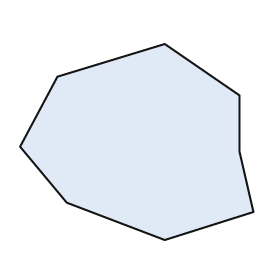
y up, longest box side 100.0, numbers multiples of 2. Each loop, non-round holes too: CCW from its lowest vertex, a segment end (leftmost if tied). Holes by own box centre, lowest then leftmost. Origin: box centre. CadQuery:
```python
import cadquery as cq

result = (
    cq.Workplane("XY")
    .moveTo(12.0, -42.0)
    .lineTo(50.0, -30.0)
    .lineTo(44.0, -4.0)
    .lineTo(44.0, 20.0)
    .lineTo(12.0, 42.0)
    .lineTo(-34.0, 28.0)
    .lineTo(-50.0, -2.0)
    .lineTo(-30.0, -26.0)
    .close()
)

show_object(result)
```